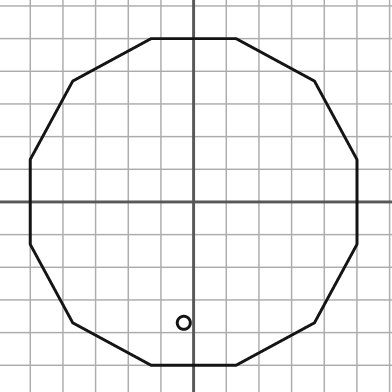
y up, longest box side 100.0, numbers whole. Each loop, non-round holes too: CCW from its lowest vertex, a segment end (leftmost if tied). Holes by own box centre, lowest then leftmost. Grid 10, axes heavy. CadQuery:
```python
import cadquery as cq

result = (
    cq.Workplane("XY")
    .moveTo(-13.0, -50.0)
    .lineTo(13.0, -50.0)
    .lineTo(37.0, -37.0)
    .lineTo(50.0, -13.0)
    .lineTo(50.0, 13.0)
    .lineTo(37.0, 37.0)
    .lineTo(13.0, 50.0)
    .lineTo(-13.0, 50.0)
    .lineTo(-37.0, 37.0)
    .lineTo(-50.0, 13.0)
    .lineTo(-50.0, -13.0)
    .lineTo(-37.0, -37.0)
    .close()
    .moveTo(-3.0, -37.0)
    .circle(2.0)
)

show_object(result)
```